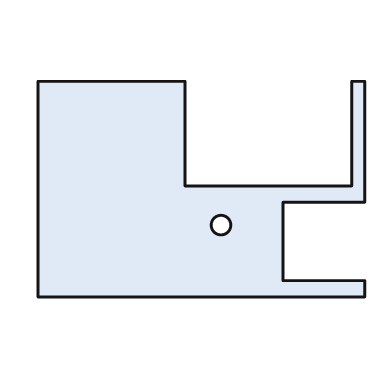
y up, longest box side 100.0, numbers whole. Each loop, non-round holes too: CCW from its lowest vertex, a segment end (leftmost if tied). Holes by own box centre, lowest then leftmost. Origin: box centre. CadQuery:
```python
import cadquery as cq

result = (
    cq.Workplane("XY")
    .moveTo(-50.0, -33.0)
    .lineTo(50.0, -33.0)
    .lineTo(50.0, -28.0)
    .lineTo(25.0, -28.0)
    .lineTo(25.0, -4.0)
    .lineTo(50.0, -4.0)
    .lineTo(50.0, 33.0)
    .lineTo(46.0, 33.0)
    .lineTo(46.0, 1.0)
    .lineTo(-5.0, 1.0)
    .lineTo(-5.0, 33.0)
    .lineTo(-50.0, 33.0)
    .close()
    .moveTo(6.0, -11.0)
    .circle(3.0)
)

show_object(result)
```